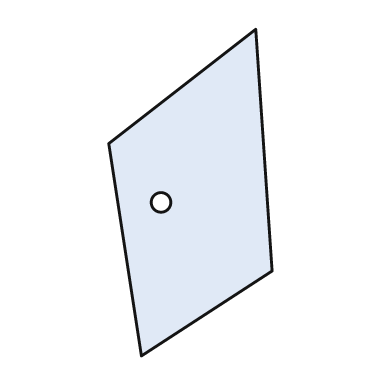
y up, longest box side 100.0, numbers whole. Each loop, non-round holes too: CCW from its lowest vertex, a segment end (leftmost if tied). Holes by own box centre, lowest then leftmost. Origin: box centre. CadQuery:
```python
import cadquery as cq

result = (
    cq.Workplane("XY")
    .moveTo(-15.0, -50.0)
    .lineTo(25.0, -24.0)
    .lineTo(20.0, 50.0)
    .lineTo(-25.0, 15.0)
    .close()
    .moveTo(-9.0, -3.0)
    .circle(3.0)
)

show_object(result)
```